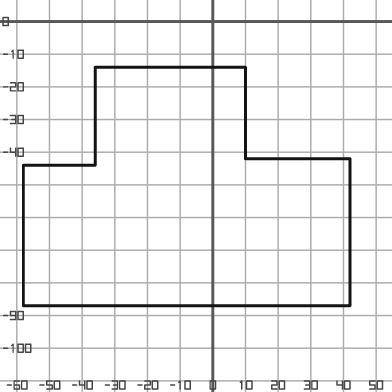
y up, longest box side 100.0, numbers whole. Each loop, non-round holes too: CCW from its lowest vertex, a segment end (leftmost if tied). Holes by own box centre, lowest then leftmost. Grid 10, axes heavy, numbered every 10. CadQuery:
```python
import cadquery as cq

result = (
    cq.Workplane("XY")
    .moveTo(-58.0, -87.0)
    .lineTo(42.0, -87.0)
    .lineTo(42.0, -42.0)
    .lineTo(10.0, -42.0)
    .lineTo(10.0, -14.0)
    .lineTo(-36.0, -14.0)
    .lineTo(-36.0, -44.0)
    .lineTo(-58.0, -44.0)
    .close()
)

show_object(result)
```